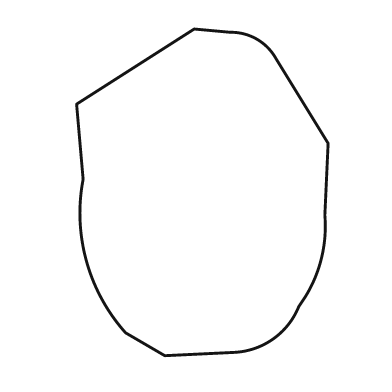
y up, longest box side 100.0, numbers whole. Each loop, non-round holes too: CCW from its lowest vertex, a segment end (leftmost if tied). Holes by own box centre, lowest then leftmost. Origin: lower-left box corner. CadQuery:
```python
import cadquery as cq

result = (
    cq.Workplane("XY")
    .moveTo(27.0, 0.0)
    .lineTo(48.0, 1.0)
    .threePointArc((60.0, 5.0), (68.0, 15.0))
    .lineTo(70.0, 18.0)
    .threePointArc((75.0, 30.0), (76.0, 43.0))
    .lineTo(77.0, 65.0)
    .lineTo(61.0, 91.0)
    .threePointArc((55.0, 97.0), (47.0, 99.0))
    .lineTo(36.0, 100.0)
    .lineTo(0.0, 77.0)
    .lineTo(2.0, 54.0)
    .threePointArc((3.0, 29.0), (15.0, 7.0))
    .close()
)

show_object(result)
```